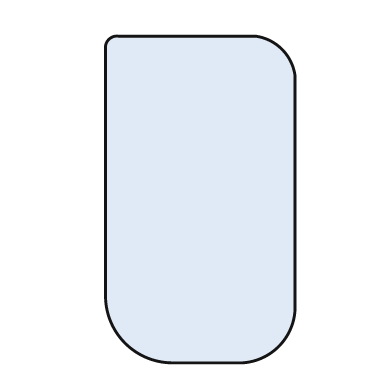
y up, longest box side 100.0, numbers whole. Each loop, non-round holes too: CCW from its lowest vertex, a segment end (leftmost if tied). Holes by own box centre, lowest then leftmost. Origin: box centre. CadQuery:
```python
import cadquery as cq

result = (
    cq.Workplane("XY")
    .moveTo(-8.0, -50.0)
    .lineTo(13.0, -50.0)
    .threePointArc((24.0, -45.0), (29.0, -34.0))
    .lineTo(29.0, 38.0)
    .threePointArc((25.0, 46.0), (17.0, 50.0))
    .lineTo(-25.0, 50.0)
    .threePointArc((-28.0, 49.0), (-29.0, 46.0))
    .lineTo(-29.0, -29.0)
    .threePointArc((-23.0, -44.0), (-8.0, -50.0))
    .close()
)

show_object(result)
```